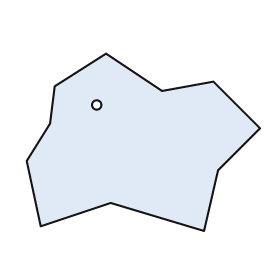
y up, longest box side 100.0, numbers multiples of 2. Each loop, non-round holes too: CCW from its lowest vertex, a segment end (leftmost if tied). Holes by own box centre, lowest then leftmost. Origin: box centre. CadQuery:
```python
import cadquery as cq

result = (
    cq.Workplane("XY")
    .moveTo(26.0, -38.0)
    .lineTo(32.0, -12.0)
    .lineTo(50.0, 6.0)
    .lineTo(30.0, 26.0)
    .lineTo(8.0, 22.0)
    .lineTo(-16.0, 38.0)
    .lineTo(-38.0, 24.0)
    .lineTo(-40.0, 8.0)
    .lineTo(-50.0, -8.0)
    .lineTo(-44.0, -36.0)
    .lineTo(-14.0, -26.0)
    .close()
    .moveTo(-20.0, 16.0)
    .circle(2.0)
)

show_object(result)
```